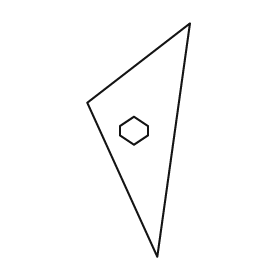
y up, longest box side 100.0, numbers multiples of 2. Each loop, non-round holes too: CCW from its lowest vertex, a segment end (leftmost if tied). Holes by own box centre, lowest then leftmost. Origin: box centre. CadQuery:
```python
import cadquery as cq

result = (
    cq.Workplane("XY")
    .moveTo(8.0, -50.0)
    .lineTo(22.0, 50.0)
    .lineTo(-22.0, 16.0)
    .close()
    .moveTo(-2.0, -2.0)
    .lineTo(4.0, 2.0)
    .lineTo(4.0, 6.0)
    .lineTo(-2.0, 10.0)
    .lineTo(-8.0, 6.0)
    .lineTo(-8.0, 2.0)
    .close()
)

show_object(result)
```